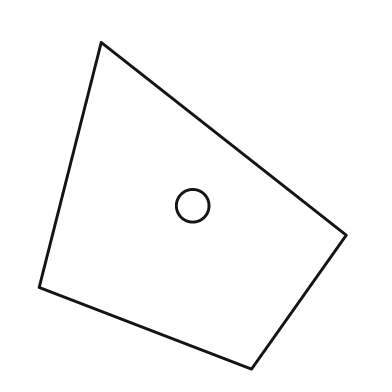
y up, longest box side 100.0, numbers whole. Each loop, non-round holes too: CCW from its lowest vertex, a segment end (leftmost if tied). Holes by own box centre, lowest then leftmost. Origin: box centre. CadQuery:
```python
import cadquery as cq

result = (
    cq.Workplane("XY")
    .moveTo(18.0, -50.0)
    .lineTo(47.0, -9.0)
    .lineTo(-28.0, 50.0)
    .lineTo(-47.0, -25.0)
    .close()
    .moveTo(0.0, 0.0)
    .circle(5.0)
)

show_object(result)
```